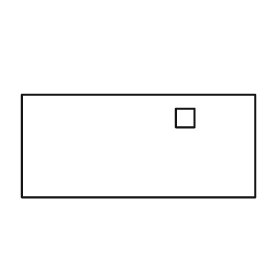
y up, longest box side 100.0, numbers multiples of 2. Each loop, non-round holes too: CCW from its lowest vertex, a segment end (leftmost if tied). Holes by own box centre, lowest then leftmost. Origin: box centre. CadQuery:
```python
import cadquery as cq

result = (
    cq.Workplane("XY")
    .moveTo(-50.0, -22.0)
    .lineTo(50.0, -22.0)
    .lineTo(50.0, 22.0)
    .lineTo(-50.0, 22.0)
    .close()
    .moveTo(16.0, 8.0)
    .lineTo(24.0, 8.0)
    .lineTo(24.0, 16.0)
    .lineTo(16.0, 16.0)
    .close()
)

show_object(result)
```